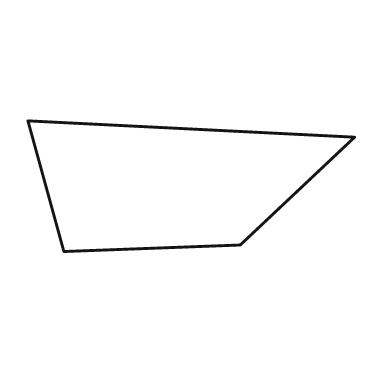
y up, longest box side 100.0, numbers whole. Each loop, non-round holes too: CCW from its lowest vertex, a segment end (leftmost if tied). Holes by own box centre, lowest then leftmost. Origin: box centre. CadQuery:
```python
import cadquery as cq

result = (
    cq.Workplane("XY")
    .moveTo(-39.0, -20.0)
    .lineTo(15.0, -18.0)
    .lineTo(50.0, 15.0)
    .lineTo(-50.0, 20.0)
    .close()
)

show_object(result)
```